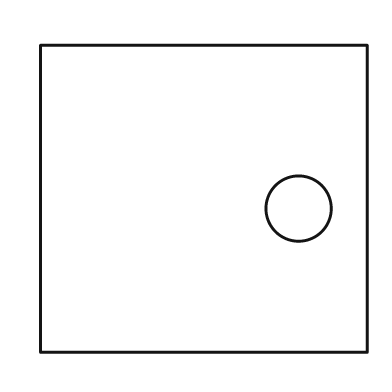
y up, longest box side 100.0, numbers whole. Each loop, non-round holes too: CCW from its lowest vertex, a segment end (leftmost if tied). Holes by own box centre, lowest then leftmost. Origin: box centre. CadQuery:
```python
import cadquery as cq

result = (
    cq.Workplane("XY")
    .moveTo(-50.0, -47.0)
    .lineTo(50.0, -47.0)
    .lineTo(50.0, 47.0)
    .lineTo(-50.0, 47.0)
    .close()
    .moveTo(29.0, -3.0)
    .circle(10.0)
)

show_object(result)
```